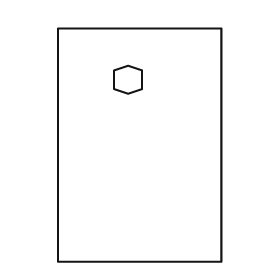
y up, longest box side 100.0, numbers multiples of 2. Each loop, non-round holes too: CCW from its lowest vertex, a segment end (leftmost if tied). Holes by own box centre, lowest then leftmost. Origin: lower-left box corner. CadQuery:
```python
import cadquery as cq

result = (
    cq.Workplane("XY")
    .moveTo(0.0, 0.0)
    .lineTo(70.0, 0.0)
    .lineTo(70.0, 100.0)
    .lineTo(0.0, 100.0)
    .close()
    .moveTo(30.0, 72.0)
    .lineTo(36.0, 74.0)
    .lineTo(36.0, 82.0)
    .lineTo(30.0, 84.0)
    .lineTo(24.0, 82.0)
    .lineTo(24.0, 74.0)
    .close()
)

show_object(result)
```